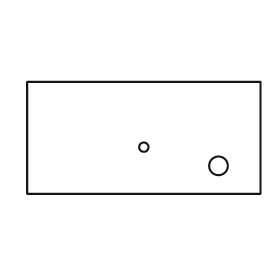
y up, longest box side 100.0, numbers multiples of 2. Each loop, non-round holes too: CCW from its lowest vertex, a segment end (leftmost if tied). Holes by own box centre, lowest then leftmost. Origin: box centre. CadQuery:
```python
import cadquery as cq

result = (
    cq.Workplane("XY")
    .moveTo(-50.0, -24.0)
    .lineTo(50.0, -24.0)
    .lineTo(50.0, 24.0)
    .lineTo(-50.0, 24.0)
    .close()
    .moveTo(32.0, -12.0)
    .circle(4.0)
    .moveTo(0.0, -4.0)
    .circle(2.0)
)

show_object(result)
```